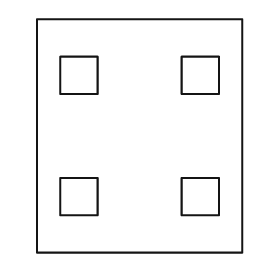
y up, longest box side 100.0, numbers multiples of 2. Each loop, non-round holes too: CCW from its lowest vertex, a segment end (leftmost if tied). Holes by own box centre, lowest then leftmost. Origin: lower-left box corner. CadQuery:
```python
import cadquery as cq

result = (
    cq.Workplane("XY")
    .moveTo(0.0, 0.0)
    .lineTo(88.0, 0.0)
    .lineTo(88.0, 100.0)
    .lineTo(0.0, 100.0)
    .close()
    .moveTo(10.0, 16.0)
    .lineTo(26.0, 16.0)
    .lineTo(26.0, 32.0)
    .lineTo(10.0, 32.0)
    .close()
    .moveTo(62.0, 16.0)
    .lineTo(78.0, 16.0)
    .lineTo(78.0, 32.0)
    .lineTo(62.0, 32.0)
    .close()
    .moveTo(10.0, 68.0)
    .lineTo(26.0, 68.0)
    .lineTo(26.0, 84.0)
    .lineTo(10.0, 84.0)
    .close()
    .moveTo(62.0, 68.0)
    .lineTo(78.0, 68.0)
    .lineTo(78.0, 84.0)
    .lineTo(62.0, 84.0)
    .close()
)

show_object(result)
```